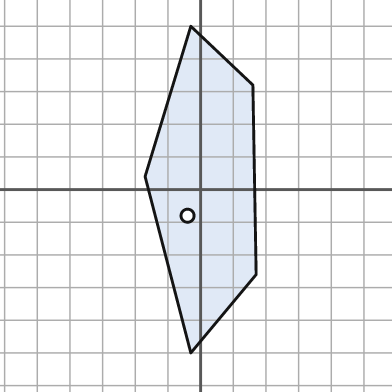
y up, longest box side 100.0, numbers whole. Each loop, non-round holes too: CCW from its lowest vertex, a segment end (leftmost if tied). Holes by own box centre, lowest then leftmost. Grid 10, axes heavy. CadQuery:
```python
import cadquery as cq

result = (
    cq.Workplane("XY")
    .moveTo(-3.0, -50.0)
    .lineTo(17.0, -26.0)
    .lineTo(16.0, 32.0)
    .lineTo(-3.0, 50.0)
    .lineTo(-17.0, 4.0)
    .close()
    .moveTo(-4.0, -8.0)
    .circle(2.0)
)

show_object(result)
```